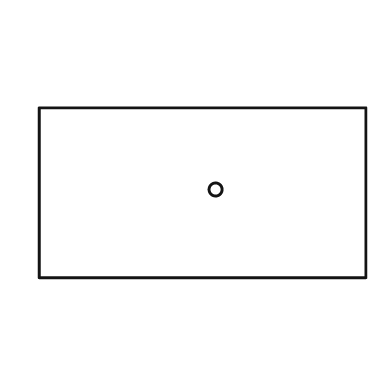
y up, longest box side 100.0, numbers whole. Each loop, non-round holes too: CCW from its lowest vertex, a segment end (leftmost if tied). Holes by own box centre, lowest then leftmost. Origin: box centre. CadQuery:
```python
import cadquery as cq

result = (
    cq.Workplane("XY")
    .moveTo(-50.0, -26.0)
    .lineTo(50.0, -26.0)
    .lineTo(50.0, 26.0)
    .lineTo(-50.0, 26.0)
    .close()
    .moveTo(4.0, 1.0)
    .circle(2.0)
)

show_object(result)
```